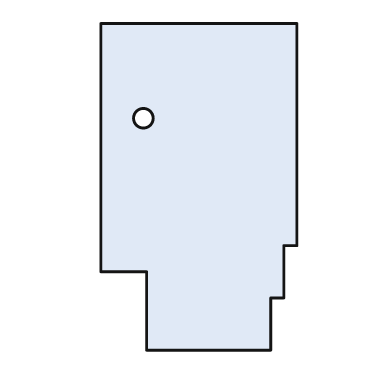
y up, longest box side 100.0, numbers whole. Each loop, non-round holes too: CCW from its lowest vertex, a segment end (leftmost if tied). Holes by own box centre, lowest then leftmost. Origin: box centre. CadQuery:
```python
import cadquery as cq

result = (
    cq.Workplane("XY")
    .moveTo(-16.0, -50.0)
    .lineTo(22.0, -50.0)
    .lineTo(22.0, -34.0)
    .lineTo(26.0, -34.0)
    .lineTo(26.0, -18.0)
    .lineTo(30.0, -18.0)
    .lineTo(30.0, 50.0)
    .lineTo(-30.0, 50.0)
    .lineTo(-30.0, -26.0)
    .lineTo(-16.0, -26.0)
    .close()
    .moveTo(-17.0, 21.0)
    .circle(3.0)
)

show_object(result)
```